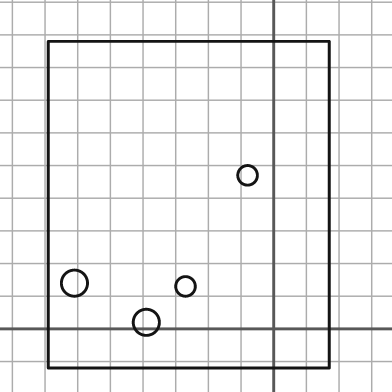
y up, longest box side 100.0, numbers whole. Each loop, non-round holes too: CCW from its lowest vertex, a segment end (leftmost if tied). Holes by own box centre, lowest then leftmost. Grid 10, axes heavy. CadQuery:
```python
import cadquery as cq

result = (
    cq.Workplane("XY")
    .moveTo(-69.0, -12.0)
    .lineTo(17.0, -12.0)
    .lineTo(17.0, 88.0)
    .lineTo(-69.0, 88.0)
    .close()
    .moveTo(-39.0, 2.0)
    .circle(4.0)
    .moveTo(-27.0, 13.0)
    .circle(3.0)
    .moveTo(-61.0, 14.0)
    .circle(4.0)
    .moveTo(-8.0, 47.0)
    .circle(3.0)
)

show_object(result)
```